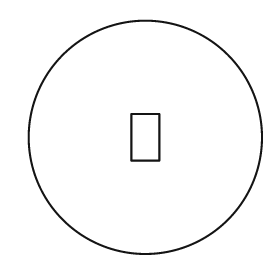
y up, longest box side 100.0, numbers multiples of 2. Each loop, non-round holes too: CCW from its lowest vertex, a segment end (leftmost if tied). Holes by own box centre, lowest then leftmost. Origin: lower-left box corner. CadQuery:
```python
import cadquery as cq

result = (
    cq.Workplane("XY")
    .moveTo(50.0, 50.0)
    .circle(50.0)
    .moveTo(44.0, 40.0)
    .lineTo(56.0, 40.0)
    .lineTo(56.0, 60.0)
    .lineTo(44.0, 60.0)
    .close()
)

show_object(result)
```